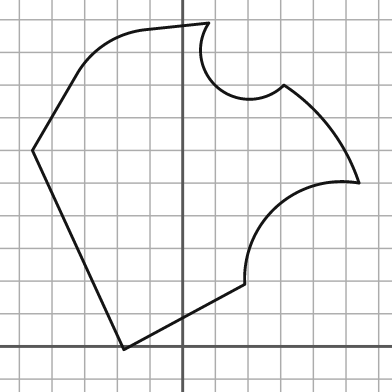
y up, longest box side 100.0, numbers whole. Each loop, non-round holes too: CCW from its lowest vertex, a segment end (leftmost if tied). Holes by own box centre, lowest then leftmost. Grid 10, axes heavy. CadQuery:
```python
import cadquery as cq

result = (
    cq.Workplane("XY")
    .moveTo(-18.0, -1.0)
    .lineTo(19.0, 19.0)
    .threePointArc((29.0, 43.0), (54.0, 50.0))
    .threePointArc((45.0, 67.0), (31.0, 80.0))
    .threePointArc((11.0, 79.0), (8.0, 99.0))
    .lineTo(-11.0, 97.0)
    .threePointArc((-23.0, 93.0), (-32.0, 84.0))
    .lineTo(-46.0, 60.0)
    .close()
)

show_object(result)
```